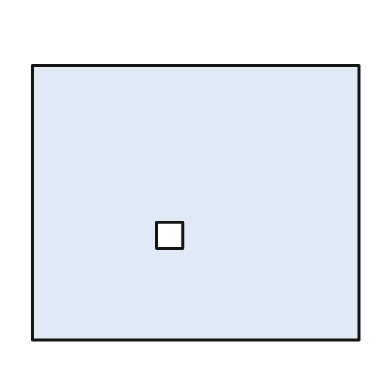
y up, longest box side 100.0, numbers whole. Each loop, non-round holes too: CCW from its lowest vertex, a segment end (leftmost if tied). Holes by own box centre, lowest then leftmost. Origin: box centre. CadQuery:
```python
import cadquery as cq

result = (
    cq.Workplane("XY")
    .moveTo(-50.0, -42.0)
    .lineTo(50.0, -42.0)
    .lineTo(50.0, 42.0)
    .lineTo(-50.0, 42.0)
    .close()
    .moveTo(-12.0, -14.0)
    .lineTo(-4.0, -14.0)
    .lineTo(-4.0, -6.0)
    .lineTo(-12.0, -6.0)
    .close()
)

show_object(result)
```